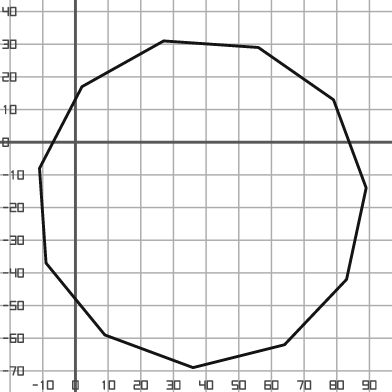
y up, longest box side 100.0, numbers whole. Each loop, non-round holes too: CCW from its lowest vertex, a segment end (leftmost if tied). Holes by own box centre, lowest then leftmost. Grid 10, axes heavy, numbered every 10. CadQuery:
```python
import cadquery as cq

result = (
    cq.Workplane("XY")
    .moveTo(36.0, -69.0)
    .lineTo(64.0, -62.0)
    .lineTo(83.0, -42.0)
    .lineTo(89.0, -14.0)
    .lineTo(79.0, 13.0)
    .lineTo(56.0, 29.0)
    .lineTo(27.0, 31.0)
    .lineTo(2.0, 17.0)
    .lineTo(-11.0, -8.0)
    .lineTo(-9.0, -37.0)
    .lineTo(9.0, -59.0)
    .close()
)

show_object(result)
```